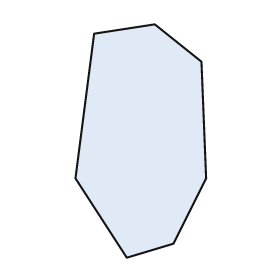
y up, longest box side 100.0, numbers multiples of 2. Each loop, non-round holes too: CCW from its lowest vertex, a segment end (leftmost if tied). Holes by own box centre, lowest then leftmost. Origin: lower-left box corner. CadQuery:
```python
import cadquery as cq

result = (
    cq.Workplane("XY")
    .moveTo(22.0, 0.0)
    .lineTo(42.0, 6.0)
    .lineTo(56.0, 34.0)
    .lineTo(54.0, 84.0)
    .lineTo(34.0, 100.0)
    .lineTo(8.0, 96.0)
    .lineTo(0.0, 34.0)
    .close()
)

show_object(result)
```